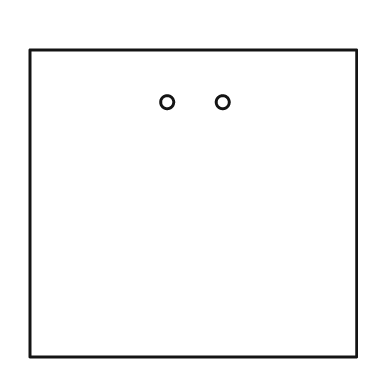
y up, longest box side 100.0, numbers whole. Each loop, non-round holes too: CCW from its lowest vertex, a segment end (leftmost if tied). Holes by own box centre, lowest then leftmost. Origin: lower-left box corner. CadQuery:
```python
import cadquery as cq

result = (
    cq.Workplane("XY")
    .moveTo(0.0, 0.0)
    .lineTo(100.0, 0.0)
    .lineTo(100.0, 94.0)
    .lineTo(0.0, 94.0)
    .close()
    .moveTo(42.0, 78.0)
    .circle(2.0)
    .moveTo(59.0, 78.0)
    .circle(2.0)
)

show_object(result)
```